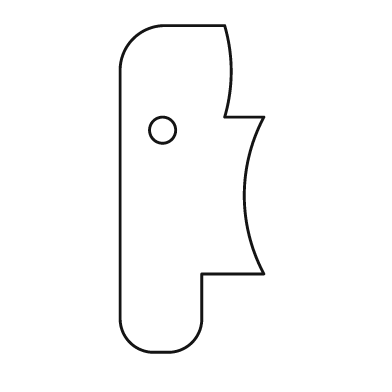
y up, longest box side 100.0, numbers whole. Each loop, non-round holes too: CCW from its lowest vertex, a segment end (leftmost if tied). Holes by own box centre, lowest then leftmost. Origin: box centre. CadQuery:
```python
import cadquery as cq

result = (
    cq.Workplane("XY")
    .moveTo(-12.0, -50.0)
    .lineTo(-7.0, -50.0)
    .threePointArc((0.0, -47.0), (3.0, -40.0))
    .lineTo(3.0, -26.0)
    .lineTo(22.0, -26.0)
    .threePointArc((16.0, -2.0), (22.0, 22.0))
    .lineTo(10.0, 22.0)
    .threePointArc((12.0, 36.0), (10.0, 50.0))
    .lineTo(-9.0, 50.0)
    .threePointArc((-18.0, 46.0), (-22.0, 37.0))
    .lineTo(-22.0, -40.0)
    .threePointArc((-19.0, -47.0), (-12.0, -50.0))
    .close()
    .moveTo(-9.0, 18.0)
    .circle(4.0)
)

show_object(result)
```